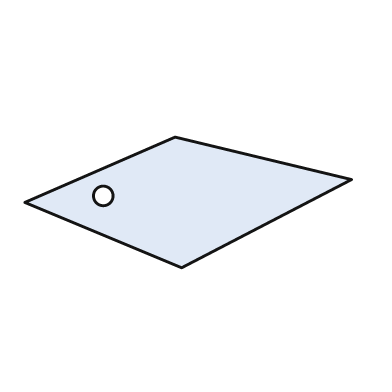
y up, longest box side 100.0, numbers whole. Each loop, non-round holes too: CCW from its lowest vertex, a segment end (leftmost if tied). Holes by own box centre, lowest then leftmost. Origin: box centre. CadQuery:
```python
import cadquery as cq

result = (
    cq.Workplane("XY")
    .moveTo(-2.0, -20.0)
    .lineTo(50.0, 7.0)
    .lineTo(-4.0, 20.0)
    .lineTo(-50.0, 0.0)
    .close()
    .moveTo(-26.0, 2.0)
    .circle(3.0)
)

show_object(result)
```